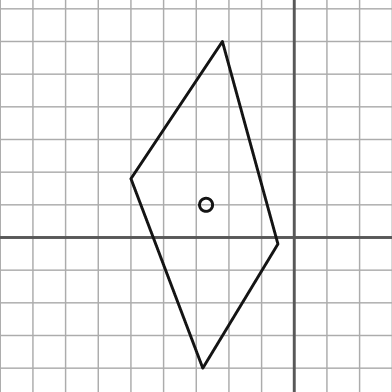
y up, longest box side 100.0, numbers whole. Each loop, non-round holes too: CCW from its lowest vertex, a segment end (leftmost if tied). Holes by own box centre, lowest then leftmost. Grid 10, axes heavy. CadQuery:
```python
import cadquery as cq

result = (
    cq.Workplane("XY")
    .moveTo(-28.0, -40.0)
    .lineTo(-5.0, -2.0)
    .lineTo(-22.0, 60.0)
    .lineTo(-50.0, 18.0)
    .close()
    .moveTo(-27.0, 10.0)
    .circle(2.0)
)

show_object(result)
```